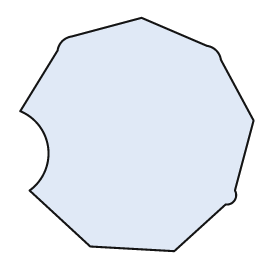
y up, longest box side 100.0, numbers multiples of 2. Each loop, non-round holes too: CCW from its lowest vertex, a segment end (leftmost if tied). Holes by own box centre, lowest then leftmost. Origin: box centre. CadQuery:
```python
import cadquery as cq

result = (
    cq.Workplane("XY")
    .moveTo(16.0, -50.0)
    .lineTo(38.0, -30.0)
    .threePointArc((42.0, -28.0), (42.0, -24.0))
    .lineTo(50.0, 6.0)
    .lineTo(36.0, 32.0)
    .threePointArc((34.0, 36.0), (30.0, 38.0))
    .lineTo(2.0, 50.0)
    .lineTo(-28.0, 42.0)
    .threePointArc((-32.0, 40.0), (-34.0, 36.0))
    .lineTo(-50.0, 10.0)
    .threePointArc((-38.0, -6.0), (-46.0, -24.0))
    .lineTo(-20.0, -48.0)
    .close()
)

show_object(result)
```